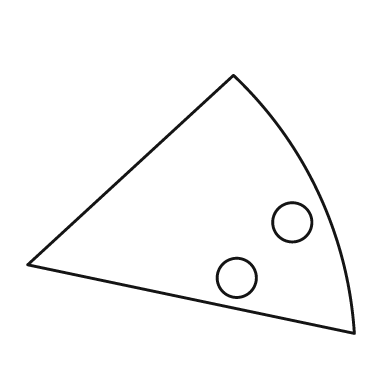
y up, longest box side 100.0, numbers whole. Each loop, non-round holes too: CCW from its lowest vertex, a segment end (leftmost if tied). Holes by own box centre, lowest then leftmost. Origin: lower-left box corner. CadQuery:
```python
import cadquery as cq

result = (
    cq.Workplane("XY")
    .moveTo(100.0, 0.0)
    .threePointArc((89.0, 43.0), (63.0, 79.0))
    .lineTo(0.0, 21.0)
    .close()
    .moveTo(64.0, 17.0)
    .circle(6.0)
    .moveTo(81.0, 34.0)
    .circle(6.0)
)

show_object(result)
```